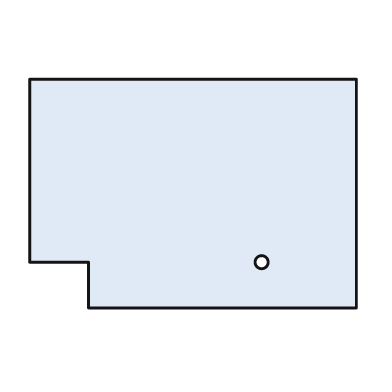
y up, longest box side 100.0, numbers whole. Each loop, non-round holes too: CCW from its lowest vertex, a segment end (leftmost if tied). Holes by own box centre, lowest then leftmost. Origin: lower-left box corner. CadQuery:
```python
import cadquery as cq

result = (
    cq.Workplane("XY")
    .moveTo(18.0, 0.0)
    .lineTo(100.0, 0.0)
    .lineTo(100.0, 70.0)
    .lineTo(0.0, 70.0)
    .lineTo(0.0, 14.0)
    .lineTo(18.0, 14.0)
    .close()
    .moveTo(71.0, 14.0)
    .circle(2.0)
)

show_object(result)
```